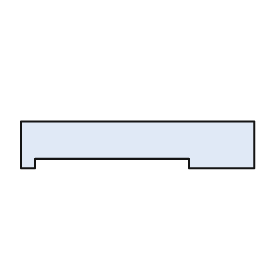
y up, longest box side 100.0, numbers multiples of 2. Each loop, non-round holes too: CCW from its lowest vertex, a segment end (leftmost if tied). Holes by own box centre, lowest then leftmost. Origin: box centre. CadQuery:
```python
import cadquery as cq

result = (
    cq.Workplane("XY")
    .moveTo(-50.0, -10.0)
    .lineTo(-44.0, -10.0)
    .lineTo(-44.0, -6.0)
    .lineTo(22.0, -6.0)
    .lineTo(22.0, -10.0)
    .lineTo(50.0, -10.0)
    .lineTo(50.0, 10.0)
    .lineTo(-50.0, 10.0)
    .close()
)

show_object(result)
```